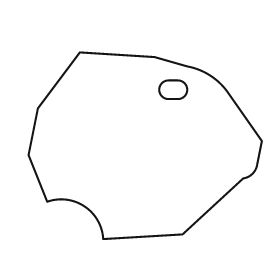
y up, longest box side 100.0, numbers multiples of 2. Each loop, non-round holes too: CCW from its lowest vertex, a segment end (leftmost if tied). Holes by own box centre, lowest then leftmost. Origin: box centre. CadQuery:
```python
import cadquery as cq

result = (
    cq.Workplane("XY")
    .moveTo(-18.0, -40.0)
    .lineTo(16.0, -38.0)
    .lineTo(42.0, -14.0)
    .threePointArc((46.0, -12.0), (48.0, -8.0))
    .lineTo(50.0, 2.0)
    .lineTo(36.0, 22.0)
    .threePointArc((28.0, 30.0), (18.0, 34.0))
    .lineTo(4.0, 38.0)
    .lineTo(-28.0, 40.0)
    .lineTo(-46.0, 16.0)
    .lineTo(-50.0, -4.0)
    .lineTo(-42.0, -24.0)
    .threePointArc((-26.0, -26.0), (-18.0, -40.0))
    .close()
    .moveTo(10.0, 20.0)
    .lineTo(14.0, 20.0)
    .threePointArc((18.0, 24.0), (14.0, 28.0))
    .lineTo(10.0, 28.0)
    .threePointArc((6.0, 24.0), (10.0, 20.0))
    .close()
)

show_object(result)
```